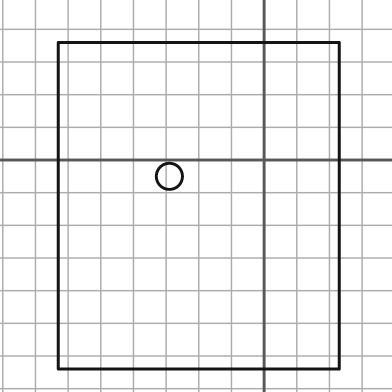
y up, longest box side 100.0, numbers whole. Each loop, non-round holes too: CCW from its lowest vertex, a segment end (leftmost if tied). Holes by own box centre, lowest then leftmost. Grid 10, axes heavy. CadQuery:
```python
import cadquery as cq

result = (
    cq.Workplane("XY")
    .moveTo(-63.0, -64.0)
    .lineTo(23.0, -64.0)
    .lineTo(23.0, 36.0)
    .lineTo(-63.0, 36.0)
    .close()
    .moveTo(-29.0, -5.0)
    .circle(4.0)
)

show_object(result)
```